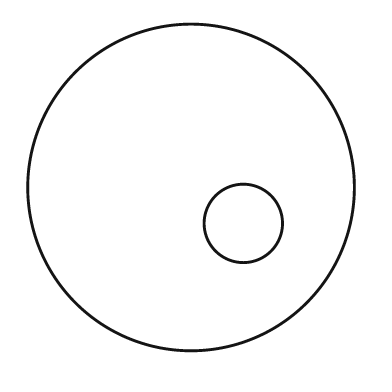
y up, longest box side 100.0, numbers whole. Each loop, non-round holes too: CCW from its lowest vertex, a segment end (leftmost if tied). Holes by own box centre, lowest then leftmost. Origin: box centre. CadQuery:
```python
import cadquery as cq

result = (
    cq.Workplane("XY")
    .moveTo(0.0, 0.0)
    .circle(50.0)
    .moveTo(16.0, -11.0)
    .circle(12.0)
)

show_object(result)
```